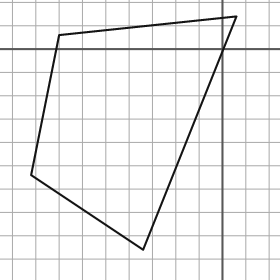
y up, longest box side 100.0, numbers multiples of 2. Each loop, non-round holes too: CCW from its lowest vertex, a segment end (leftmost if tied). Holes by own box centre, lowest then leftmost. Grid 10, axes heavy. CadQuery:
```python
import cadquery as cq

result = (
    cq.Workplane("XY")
    .moveTo(-34.0, -86.0)
    .lineTo(6.0, 14.0)
    .lineTo(-70.0, 6.0)
    .lineTo(-82.0, -54.0)
    .close()
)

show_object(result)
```